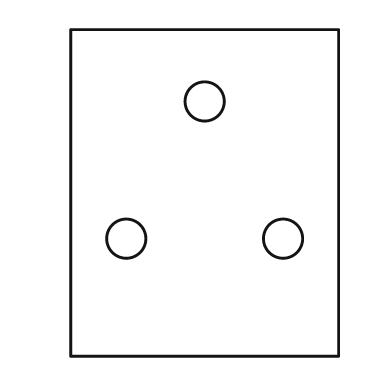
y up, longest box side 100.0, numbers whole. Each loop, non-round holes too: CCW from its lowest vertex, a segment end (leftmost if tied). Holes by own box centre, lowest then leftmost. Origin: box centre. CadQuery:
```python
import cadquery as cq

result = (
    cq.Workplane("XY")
    .moveTo(-41.0, -50.0)
    .lineTo(41.0, -50.0)
    .lineTo(41.0, 50.0)
    .lineTo(-41.0, 50.0)
    .close()
    .moveTo(-24.0, -14.0)
    .circle(6.0)
    .moveTo(24.0, -14.0)
    .circle(6.0)
    .moveTo(0.0, 28.0)
    .circle(6.0)
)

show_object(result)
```